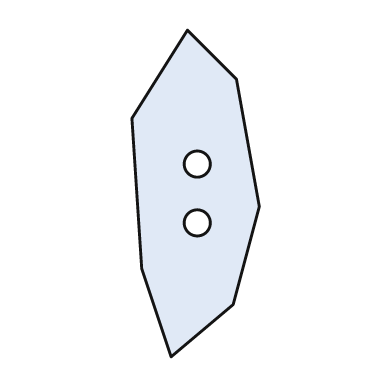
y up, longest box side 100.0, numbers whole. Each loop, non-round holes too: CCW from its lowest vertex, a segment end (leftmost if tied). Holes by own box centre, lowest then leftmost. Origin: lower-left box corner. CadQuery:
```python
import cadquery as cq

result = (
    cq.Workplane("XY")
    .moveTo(12.0, 0.0)
    .lineTo(31.0, 16.0)
    .lineTo(39.0, 46.0)
    .lineTo(32.0, 85.0)
    .lineTo(17.0, 100.0)
    .lineTo(0.0, 73.0)
    .lineTo(3.0, 27.0)
    .close()
    .moveTo(20.0, 41.0)
    .circle(4.0)
    .moveTo(20.0, 59.0)
    .circle(4.0)
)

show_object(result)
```